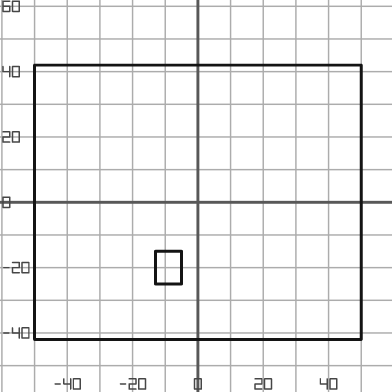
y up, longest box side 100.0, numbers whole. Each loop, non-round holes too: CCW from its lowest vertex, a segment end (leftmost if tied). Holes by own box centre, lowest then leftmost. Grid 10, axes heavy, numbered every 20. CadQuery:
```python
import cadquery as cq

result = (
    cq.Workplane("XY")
    .moveTo(-50.0, -42.0)
    .lineTo(50.0, -42.0)
    .lineTo(50.0, 42.0)
    .lineTo(-50.0, 42.0)
    .close()
    .moveTo(-13.0, -25.0)
    .lineTo(-5.0, -25.0)
    .lineTo(-5.0, -15.0)
    .lineTo(-13.0, -15.0)
    .close()
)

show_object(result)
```